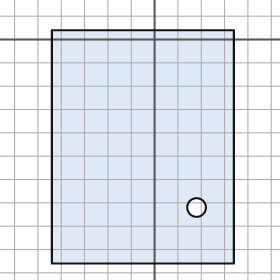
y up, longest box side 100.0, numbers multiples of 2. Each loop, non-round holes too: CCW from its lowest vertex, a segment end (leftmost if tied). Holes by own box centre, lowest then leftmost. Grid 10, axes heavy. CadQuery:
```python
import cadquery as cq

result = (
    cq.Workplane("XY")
    .moveTo(-44.0, -96.0)
    .lineTo(34.0, -96.0)
    .lineTo(34.0, 4.0)
    .lineTo(-44.0, 4.0)
    .close()
    .moveTo(18.0, -72.0)
    .circle(4.0)
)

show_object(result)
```